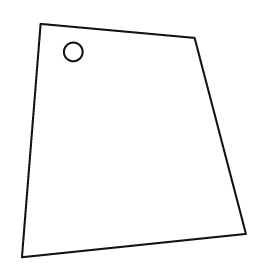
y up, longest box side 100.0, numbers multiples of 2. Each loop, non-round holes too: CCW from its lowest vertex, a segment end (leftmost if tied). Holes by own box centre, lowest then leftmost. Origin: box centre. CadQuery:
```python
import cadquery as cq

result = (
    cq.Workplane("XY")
    .moveTo(-48.0, -50.0)
    .lineTo(48.0, -40.0)
    .lineTo(26.0, 44.0)
    .lineTo(-40.0, 50.0)
    .close()
    .moveTo(-26.0, 38.0)
    .circle(4.0)
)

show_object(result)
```